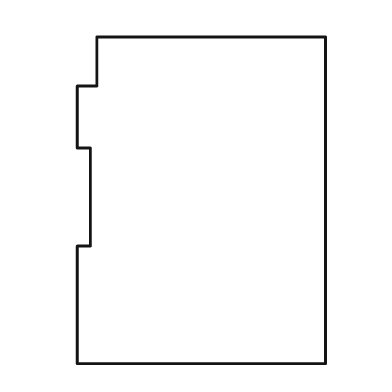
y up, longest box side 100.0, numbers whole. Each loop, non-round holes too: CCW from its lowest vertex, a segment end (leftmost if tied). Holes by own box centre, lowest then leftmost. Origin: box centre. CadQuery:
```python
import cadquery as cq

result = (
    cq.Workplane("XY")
    .moveTo(-38.0, -50.0)
    .lineTo(38.0, -50.0)
    .lineTo(38.0, 50.0)
    .lineTo(-32.0, 50.0)
    .lineTo(-32.0, 35.0)
    .lineTo(-38.0, 35.0)
    .lineTo(-38.0, 16.0)
    .lineTo(-34.0, 16.0)
    .lineTo(-34.0, -14.0)
    .lineTo(-38.0, -14.0)
    .close()
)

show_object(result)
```